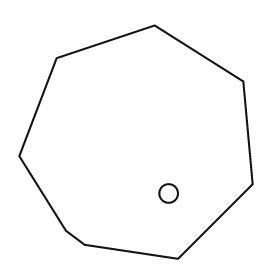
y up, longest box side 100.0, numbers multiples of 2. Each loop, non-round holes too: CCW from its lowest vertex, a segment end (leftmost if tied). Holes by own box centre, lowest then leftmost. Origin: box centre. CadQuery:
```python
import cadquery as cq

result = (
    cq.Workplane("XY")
    .moveTo(18.0, -50.0)
    .lineTo(50.0, -18.0)
    .lineTo(46.0, 26.0)
    .lineTo(8.0, 50.0)
    .lineTo(-34.0, 36.0)
    .lineTo(-50.0, -6.0)
    .lineTo(-30.0, -38.0)
    .lineTo(-22.0, -44.0)
    .close()
    .moveTo(14.0, -22.0)
    .circle(4.0)
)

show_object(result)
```